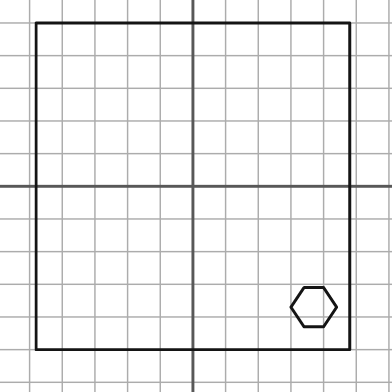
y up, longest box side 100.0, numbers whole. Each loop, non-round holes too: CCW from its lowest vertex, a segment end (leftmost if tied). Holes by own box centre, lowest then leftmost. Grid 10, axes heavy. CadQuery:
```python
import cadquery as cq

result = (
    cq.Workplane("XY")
    .moveTo(-48.0, -50.0)
    .lineTo(48.0, -50.0)
    .lineTo(48.0, 50.0)
    .lineTo(-48.0, 50.0)
    .close()
    .moveTo(34.0, -43.0)
    .lineTo(40.0, -43.0)
    .lineTo(44.0, -37.0)
    .lineTo(40.0, -31.0)
    .lineTo(34.0, -31.0)
    .lineTo(30.0, -37.0)
    .close()
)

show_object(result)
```